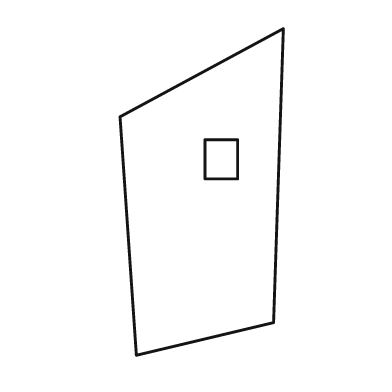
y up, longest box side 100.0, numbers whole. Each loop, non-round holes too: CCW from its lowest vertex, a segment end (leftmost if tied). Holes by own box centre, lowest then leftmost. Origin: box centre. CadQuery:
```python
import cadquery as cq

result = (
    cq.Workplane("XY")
    .moveTo(-20.0, -50.0)
    .lineTo(22.0, -40.0)
    .lineTo(25.0, 50.0)
    .lineTo(-25.0, 23.0)
    .close()
    .moveTo(1.0, 4.0)
    .lineTo(11.0, 4.0)
    .lineTo(11.0, 16.0)
    .lineTo(1.0, 16.0)
    .close()
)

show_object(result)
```